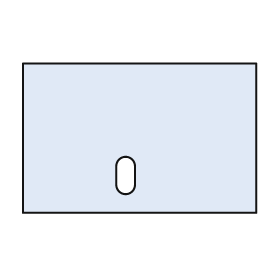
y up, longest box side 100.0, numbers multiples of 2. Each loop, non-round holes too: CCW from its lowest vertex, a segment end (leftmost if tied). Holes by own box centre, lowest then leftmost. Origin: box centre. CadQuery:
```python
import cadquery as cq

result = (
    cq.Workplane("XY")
    .moveTo(-50.0, -32.0)
    .lineTo(50.0, -32.0)
    .lineTo(50.0, 32.0)
    .lineTo(-50.0, 32.0)
    .close()
    .moveTo(-10.0, -20.0)
    .threePointArc((-6.0, -24.0), (-2.0, -20.0))
    .lineTo(-2.0, -12.0)
    .threePointArc((-6.0, -8.0), (-10.0, -12.0))
    .close()
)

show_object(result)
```